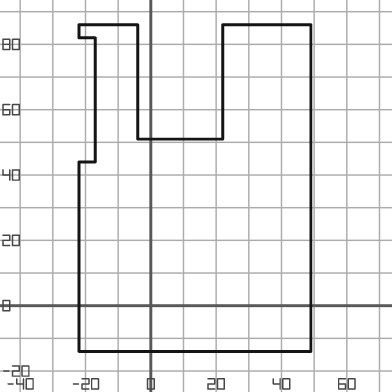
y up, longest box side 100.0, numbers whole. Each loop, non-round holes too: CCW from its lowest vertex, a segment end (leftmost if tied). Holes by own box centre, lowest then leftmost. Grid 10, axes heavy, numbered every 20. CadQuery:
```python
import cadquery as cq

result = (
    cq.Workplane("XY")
    .moveTo(-22.0, -14.0)
    .lineTo(49.0, -14.0)
    .lineTo(49.0, 86.0)
    .lineTo(22.0, 86.0)
    .lineTo(22.0, 51.0)
    .lineTo(-4.0, 51.0)
    .lineTo(-4.0, 86.0)
    .lineTo(-22.0, 86.0)
    .lineTo(-22.0, 82.0)
    .lineTo(-17.0, 82.0)
    .lineTo(-17.0, 44.0)
    .lineTo(-22.0, 44.0)
    .close()
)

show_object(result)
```